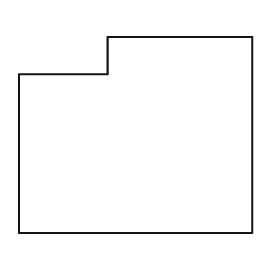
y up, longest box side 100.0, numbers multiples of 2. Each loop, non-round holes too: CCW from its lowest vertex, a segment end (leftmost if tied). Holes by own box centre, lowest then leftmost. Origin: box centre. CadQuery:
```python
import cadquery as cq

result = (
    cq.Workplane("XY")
    .moveTo(-50.0, -42.0)
    .lineTo(50.0, -42.0)
    .lineTo(50.0, 42.0)
    .lineTo(-12.0, 42.0)
    .lineTo(-12.0, 26.0)
    .lineTo(-50.0, 26.0)
    .close()
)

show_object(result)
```